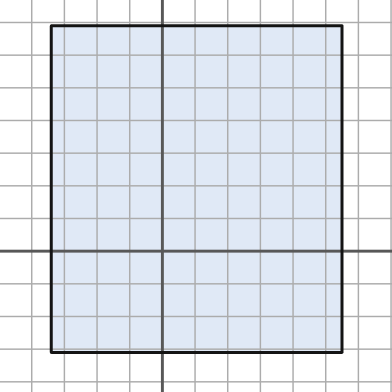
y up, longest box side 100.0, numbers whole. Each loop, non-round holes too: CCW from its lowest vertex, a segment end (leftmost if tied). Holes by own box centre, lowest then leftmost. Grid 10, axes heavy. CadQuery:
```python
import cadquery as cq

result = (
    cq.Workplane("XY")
    .moveTo(-34.0, -31.0)
    .lineTo(55.0, -31.0)
    .lineTo(55.0, 69.0)
    .lineTo(-34.0, 69.0)
    .close()
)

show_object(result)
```